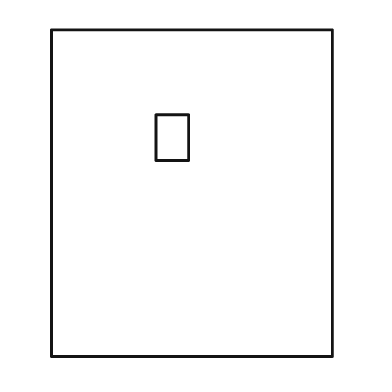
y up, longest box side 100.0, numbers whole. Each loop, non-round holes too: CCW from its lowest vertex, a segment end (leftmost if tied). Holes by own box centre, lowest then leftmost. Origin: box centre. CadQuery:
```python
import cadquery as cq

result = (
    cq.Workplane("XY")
    .moveTo(-43.0, -50.0)
    .lineTo(43.0, -50.0)
    .lineTo(43.0, 50.0)
    .lineTo(-43.0, 50.0)
    .close()
    .moveTo(-11.0, 10.0)
    .lineTo(-1.0, 10.0)
    .lineTo(-1.0, 24.0)
    .lineTo(-11.0, 24.0)
    .close()
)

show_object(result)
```